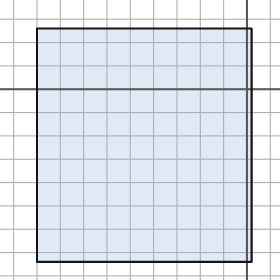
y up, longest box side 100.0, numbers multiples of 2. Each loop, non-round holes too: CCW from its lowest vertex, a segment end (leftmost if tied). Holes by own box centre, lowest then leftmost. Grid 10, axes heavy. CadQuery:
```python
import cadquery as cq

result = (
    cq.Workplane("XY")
    .moveTo(-90.0, -74.0)
    .lineTo(2.0, -74.0)
    .lineTo(2.0, 26.0)
    .lineTo(-90.0, 26.0)
    .close()
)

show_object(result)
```